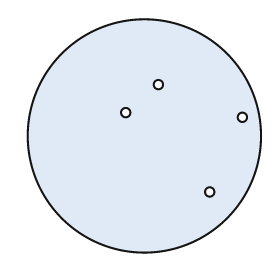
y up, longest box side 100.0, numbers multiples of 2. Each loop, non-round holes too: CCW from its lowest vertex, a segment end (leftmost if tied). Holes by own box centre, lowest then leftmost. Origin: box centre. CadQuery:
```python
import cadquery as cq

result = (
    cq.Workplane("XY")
    .moveTo(0.0, 0.0)
    .circle(50.0)
    .moveTo(28.0, -24.0)
    .circle(2.0)
    .moveTo(42.0, 8.0)
    .circle(2.0)
    .moveTo(-8.0, 10.0)
    .circle(2.0)
    .moveTo(6.0, 22.0)
    .circle(2.0)
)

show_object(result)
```